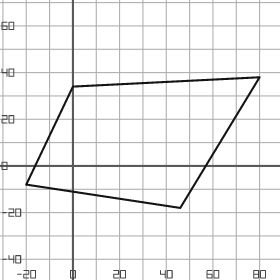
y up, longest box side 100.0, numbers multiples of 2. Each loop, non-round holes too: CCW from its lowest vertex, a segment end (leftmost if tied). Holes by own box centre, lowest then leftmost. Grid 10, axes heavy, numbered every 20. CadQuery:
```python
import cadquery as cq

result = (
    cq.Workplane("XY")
    .moveTo(46.0, -18.0)
    .lineTo(80.0, 38.0)
    .lineTo(0.0, 34.0)
    .lineTo(-20.0, -8.0)
    .close()
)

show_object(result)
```